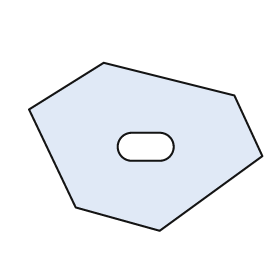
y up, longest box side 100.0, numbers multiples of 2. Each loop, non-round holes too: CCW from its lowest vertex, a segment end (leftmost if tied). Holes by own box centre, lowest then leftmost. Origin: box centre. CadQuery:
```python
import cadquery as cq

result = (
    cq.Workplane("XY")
    .moveTo(6.0, -36.0)
    .lineTo(50.0, -4.0)
    .lineTo(38.0, 22.0)
    .lineTo(-18.0, 36.0)
    .lineTo(-50.0, 16.0)
    .lineTo(-30.0, -26.0)
    .close()
    .moveTo(-6.0, -6.0)
    .lineTo(6.0, -6.0)
    .threePointArc((12.0, 0.0), (6.0, 6.0))
    .lineTo(-6.0, 6.0)
    .threePointArc((-12.0, 0.0), (-6.0, -6.0))
    .close()
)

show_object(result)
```